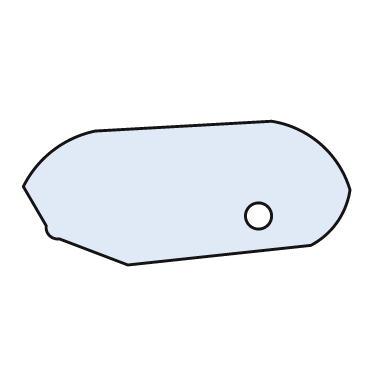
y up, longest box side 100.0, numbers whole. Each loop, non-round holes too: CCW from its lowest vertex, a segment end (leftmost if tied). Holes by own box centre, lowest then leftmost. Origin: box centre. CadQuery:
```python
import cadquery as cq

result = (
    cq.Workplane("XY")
    .moveTo(-18.0, -22.0)
    .lineTo(38.0, -16.0)
    .threePointArc((46.0, -9.0), (50.0, 1.0))
    .threePointArc((41.0, 15.0), (26.0, 22.0))
    .lineTo(-28.0, 19.0)
    .threePointArc((-41.0, 13.0), (-50.0, 2.0))
    .lineTo(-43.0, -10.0)
    .threePointArc((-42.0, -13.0), (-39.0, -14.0))
    .close()
    .moveTo(22.0, -7.0)
    .circle(4.0)
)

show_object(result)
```